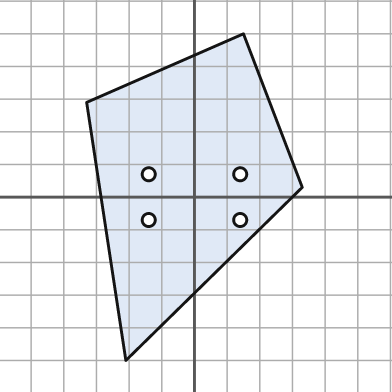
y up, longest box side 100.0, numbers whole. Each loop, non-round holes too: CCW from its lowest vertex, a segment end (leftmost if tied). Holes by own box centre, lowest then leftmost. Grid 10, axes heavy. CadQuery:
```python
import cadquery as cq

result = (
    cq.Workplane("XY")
    .moveTo(-21.0, -50.0)
    .lineTo(33.0, 3.0)
    .lineTo(15.0, 50.0)
    .lineTo(-33.0, 29.0)
    .close()
    .moveTo(-14.0, -7.0)
    .circle(2.0)
    .moveTo(14.0, -7.0)
    .circle(2.0)
    .moveTo(-14.0, 7.0)
    .circle(2.0)
    .moveTo(14.0, 7.0)
    .circle(2.0)
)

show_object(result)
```